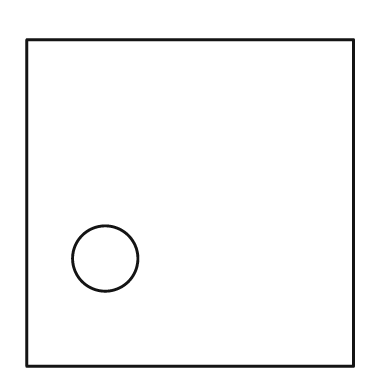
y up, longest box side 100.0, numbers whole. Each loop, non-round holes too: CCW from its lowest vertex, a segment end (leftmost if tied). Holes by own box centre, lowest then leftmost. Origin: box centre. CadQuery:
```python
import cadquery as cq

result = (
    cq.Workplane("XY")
    .moveTo(-50.0, -50.0)
    .lineTo(50.0, -50.0)
    .lineTo(50.0, 50.0)
    .lineTo(-50.0, 50.0)
    .close()
    .moveTo(-26.0, -17.0)
    .circle(10.0)
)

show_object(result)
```